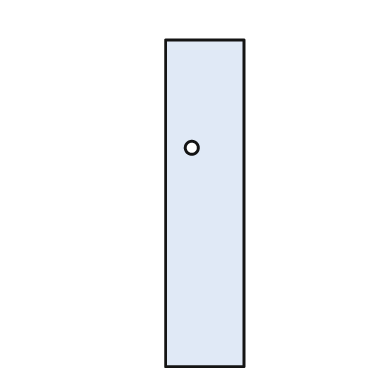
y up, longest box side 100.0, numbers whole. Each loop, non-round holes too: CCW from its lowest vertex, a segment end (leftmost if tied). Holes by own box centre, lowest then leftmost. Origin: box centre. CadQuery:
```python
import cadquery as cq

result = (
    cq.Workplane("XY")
    .moveTo(-12.0, -50.0)
    .lineTo(12.0, -50.0)
    .lineTo(12.0, 50.0)
    .lineTo(-12.0, 50.0)
    .close()
    .moveTo(-4.0, 17.0)
    .circle(2.0)
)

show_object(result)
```